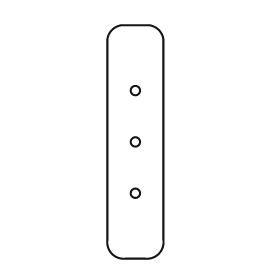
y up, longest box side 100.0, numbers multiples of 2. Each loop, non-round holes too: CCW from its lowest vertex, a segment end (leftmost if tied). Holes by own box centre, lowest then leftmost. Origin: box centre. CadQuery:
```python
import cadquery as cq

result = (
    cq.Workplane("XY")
    .moveTo(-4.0, -50.0)
    .lineTo(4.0, -50.0)
    .threePointArc((10.0, -48.0), (12.0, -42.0))
    .lineTo(12.0, 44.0)
    .threePointArc((10.0, 48.0), (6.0, 50.0))
    .lineTo(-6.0, 50.0)
    .threePointArc((-10.0, 48.0), (-12.0, 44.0))
    .lineTo(-12.0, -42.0)
    .threePointArc((-10.0, -48.0), (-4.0, -50.0))
    .close()
    .moveTo(0.0, -22.0)
    .circle(2.0)
    .moveTo(0.0, 0.0)
    .circle(2.0)
    .moveTo(0.0, 22.0)
    .circle(2.0)
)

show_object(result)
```